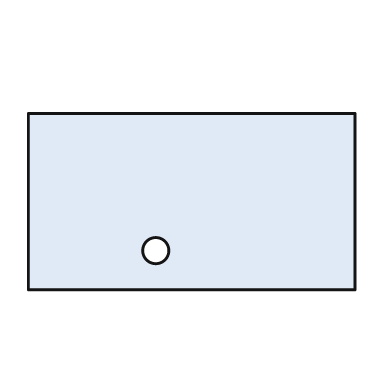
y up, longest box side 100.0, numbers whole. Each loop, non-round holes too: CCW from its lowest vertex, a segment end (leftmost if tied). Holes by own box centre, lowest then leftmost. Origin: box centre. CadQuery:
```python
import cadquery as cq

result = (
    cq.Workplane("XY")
    .moveTo(-50.0, -27.0)
    .lineTo(50.0, -27.0)
    .lineTo(50.0, 27.0)
    .lineTo(-50.0, 27.0)
    .close()
    .moveTo(-11.0, -15.0)
    .circle(4.0)
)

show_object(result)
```